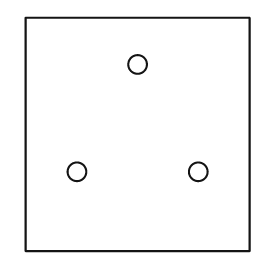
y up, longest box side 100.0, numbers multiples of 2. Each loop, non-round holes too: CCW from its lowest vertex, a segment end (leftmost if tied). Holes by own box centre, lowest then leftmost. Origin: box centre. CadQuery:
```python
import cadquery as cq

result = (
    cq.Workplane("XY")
    .moveTo(-48.0, -50.0)
    .lineTo(48.0, -50.0)
    .lineTo(48.0, 50.0)
    .lineTo(-48.0, 50.0)
    .close()
    .moveTo(-26.0, -16.0)
    .circle(4.0)
    .moveTo(26.0, -16.0)
    .circle(4.0)
    .moveTo(0.0, 30.0)
    .circle(4.0)
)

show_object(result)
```